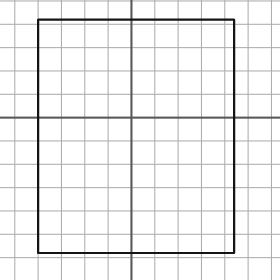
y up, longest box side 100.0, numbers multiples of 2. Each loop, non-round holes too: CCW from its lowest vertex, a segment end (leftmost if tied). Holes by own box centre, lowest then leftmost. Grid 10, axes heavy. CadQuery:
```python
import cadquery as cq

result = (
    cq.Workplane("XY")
    .moveTo(-40.0, -58.0)
    .lineTo(44.0, -58.0)
    .lineTo(44.0, 42.0)
    .lineTo(-40.0, 42.0)
    .close()
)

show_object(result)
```